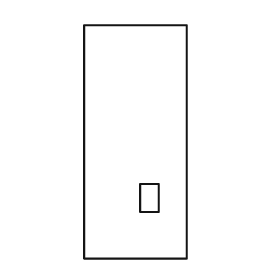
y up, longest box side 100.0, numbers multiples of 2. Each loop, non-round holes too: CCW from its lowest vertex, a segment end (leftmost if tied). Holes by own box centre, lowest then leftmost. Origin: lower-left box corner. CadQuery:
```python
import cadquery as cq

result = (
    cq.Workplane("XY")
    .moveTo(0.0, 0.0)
    .lineTo(44.0, 0.0)
    .lineTo(44.0, 100.0)
    .lineTo(0.0, 100.0)
    .close()
    .moveTo(24.0, 20.0)
    .lineTo(32.0, 20.0)
    .lineTo(32.0, 32.0)
    .lineTo(24.0, 32.0)
    .close()
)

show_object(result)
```